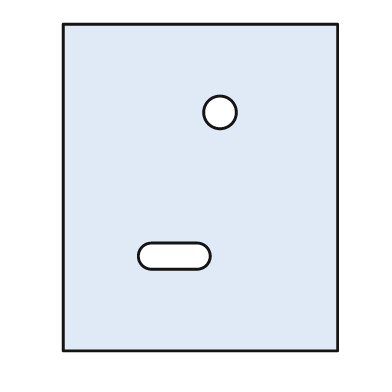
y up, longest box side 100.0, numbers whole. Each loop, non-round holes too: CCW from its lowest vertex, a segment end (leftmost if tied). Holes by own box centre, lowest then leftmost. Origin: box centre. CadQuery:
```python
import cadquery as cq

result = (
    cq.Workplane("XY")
    .moveTo(-42.0, -50.0)
    .lineTo(42.0, -50.0)
    .lineTo(42.0, 50.0)
    .lineTo(-42.0, 50.0)
    .close()
    .moveTo(-15.0, -25.0)
    .lineTo(-1.0, -25.0)
    .threePointArc((3.0, -21.0), (-1.0, -17.0))
    .lineTo(-15.0, -17.0)
    .threePointArc((-19.0, -21.0), (-15.0, -25.0))
    .close()
    .moveTo(6.0, 23.0)
    .circle(5.0)
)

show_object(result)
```